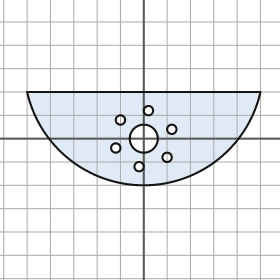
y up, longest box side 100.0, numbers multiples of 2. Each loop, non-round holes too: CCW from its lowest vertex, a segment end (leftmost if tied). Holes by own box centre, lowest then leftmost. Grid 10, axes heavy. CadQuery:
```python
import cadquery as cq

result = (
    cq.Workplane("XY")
    .moveTo(-50.0, 20.0)
    .threePointArc((0.0, -20.0), (50.0, 20.0))
    .close()
    .moveTo(-2.0, -12.0)
    .circle(2.0)
    .moveTo(10.0, -8.0)
    .circle(2.0)
    .moveTo(-12.0, -4.0)
    .circle(2.0)
    .moveTo(0.0, 0.0)
    .circle(6.0)
    .moveTo(12.0, 4.0)
    .circle(2.0)
    .moveTo(-10.0, 8.0)
    .circle(2.0)
    .moveTo(2.0, 12.0)
    .circle(2.0)
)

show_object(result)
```